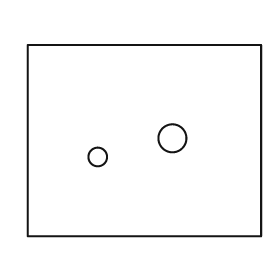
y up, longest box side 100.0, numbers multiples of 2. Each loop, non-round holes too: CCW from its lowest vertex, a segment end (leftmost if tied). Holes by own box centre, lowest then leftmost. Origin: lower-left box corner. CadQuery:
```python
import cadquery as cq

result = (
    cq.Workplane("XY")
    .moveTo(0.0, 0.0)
    .lineTo(100.0, 0.0)
    .lineTo(100.0, 82.0)
    .lineTo(0.0, 82.0)
    .close()
    .moveTo(30.0, 34.0)
    .circle(4.0)
    .moveTo(62.0, 42.0)
    .circle(6.0)
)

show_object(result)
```